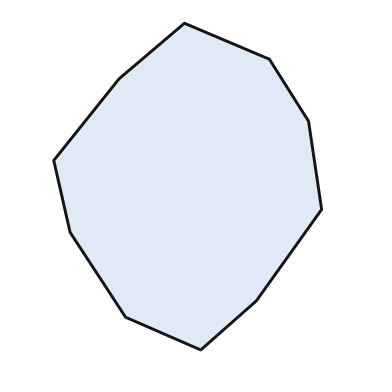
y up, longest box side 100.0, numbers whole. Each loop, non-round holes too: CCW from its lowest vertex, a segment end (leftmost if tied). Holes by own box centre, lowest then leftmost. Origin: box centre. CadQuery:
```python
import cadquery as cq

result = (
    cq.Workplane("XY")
    .moveTo(4.0, -50.0)
    .lineTo(21.0, -35.0)
    .lineTo(41.0, -7.0)
    .lineTo(37.0, 20.0)
    .lineTo(25.0, 39.0)
    .lineTo(-1.0, 50.0)
    .lineTo(-21.0, 33.0)
    .lineTo(-41.0, 8.0)
    .lineTo(-36.0, -14.0)
    .lineTo(-19.0, -40.0)
    .close()
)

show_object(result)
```